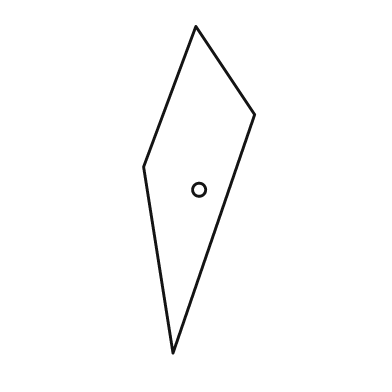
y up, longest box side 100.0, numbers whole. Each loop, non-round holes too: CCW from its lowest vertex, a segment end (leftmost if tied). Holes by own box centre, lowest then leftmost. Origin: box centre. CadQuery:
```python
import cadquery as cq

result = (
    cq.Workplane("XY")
    .moveTo(-8.0, -50.0)
    .lineTo(17.0, 23.0)
    .lineTo(-1.0, 50.0)
    .lineTo(-17.0, 7.0)
    .close()
    .moveTo(0.0, 0.0)
    .circle(2.0)
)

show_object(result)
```